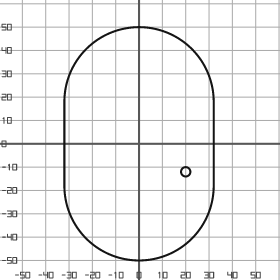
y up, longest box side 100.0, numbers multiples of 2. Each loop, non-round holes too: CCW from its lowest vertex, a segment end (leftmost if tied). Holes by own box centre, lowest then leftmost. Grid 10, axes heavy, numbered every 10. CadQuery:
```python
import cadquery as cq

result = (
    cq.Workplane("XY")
    .moveTo(-32.0, -18.0)
    .threePointArc((0.0, -50.0), (32.0, -18.0))
    .lineTo(32.0, 18.0)
    .threePointArc((0.0, 50.0), (-32.0, 18.0))
    .close()
    .moveTo(20.0, -12.0)
    .circle(2.0)
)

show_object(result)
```